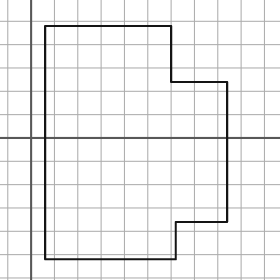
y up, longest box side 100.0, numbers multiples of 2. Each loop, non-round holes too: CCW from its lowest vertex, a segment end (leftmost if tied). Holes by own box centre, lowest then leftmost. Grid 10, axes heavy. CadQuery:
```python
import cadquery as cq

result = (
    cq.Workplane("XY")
    .moveTo(6.0, -52.0)
    .lineTo(62.0, -52.0)
    .lineTo(62.0, -36.0)
    .lineTo(84.0, -36.0)
    .lineTo(84.0, 24.0)
    .lineTo(60.0, 24.0)
    .lineTo(60.0, 48.0)
    .lineTo(6.0, 48.0)
    .close()
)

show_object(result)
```